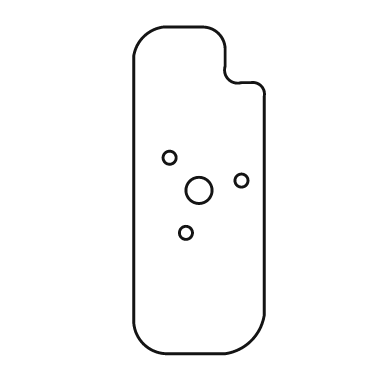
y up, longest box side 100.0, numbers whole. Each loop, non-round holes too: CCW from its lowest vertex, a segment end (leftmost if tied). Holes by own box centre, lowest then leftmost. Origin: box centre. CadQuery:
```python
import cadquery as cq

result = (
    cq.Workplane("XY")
    .moveTo(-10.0, -50.0)
    .lineTo(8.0, -50.0)
    .threePointArc((16.0, -46.0), (20.0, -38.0))
    .lineTo(20.0, 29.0)
    .threePointArc((19.0, 32.0), (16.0, 33.0))
    .lineTo(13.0, 33.0)
    .threePointArc((9.0, 34.0), (8.0, 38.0))
    .lineTo(8.0, 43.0)
    .threePointArc((6.0, 48.0), (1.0, 50.0))
    .lineTo(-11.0, 50.0)
    .threePointArc((-17.0, 47.0), (-20.0, 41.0))
    .lineTo(-20.0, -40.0)
    .threePointArc((-17.0, -47.0), (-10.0, -50.0))
    .close()
    .moveTo(-4.0, -13.0)
    .circle(2.0)
    .moveTo(0.0, 0.0)
    .circle(4.0)
    .moveTo(13.0, 3.0)
    .circle(2.0)
    .moveTo(-9.0, 10.0)
    .circle(2.0)
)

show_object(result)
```